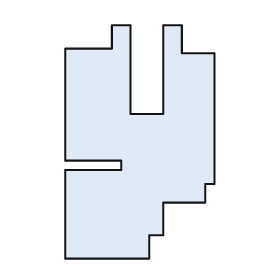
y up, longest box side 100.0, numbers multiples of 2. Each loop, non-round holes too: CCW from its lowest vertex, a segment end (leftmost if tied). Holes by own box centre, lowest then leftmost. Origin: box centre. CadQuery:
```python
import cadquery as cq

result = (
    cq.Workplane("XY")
    .moveTo(-32.0, -50.0)
    .lineTo(4.0, -50.0)
    .lineTo(4.0, -40.0)
    .lineTo(10.0, -40.0)
    .lineTo(10.0, -26.0)
    .lineTo(28.0, -26.0)
    .lineTo(28.0, -18.0)
    .lineTo(32.0, -18.0)
    .lineTo(32.0, 38.0)
    .lineTo(18.0, 38.0)
    .lineTo(18.0, 50.0)
    .lineTo(10.0, 50.0)
    .lineTo(10.0, 12.0)
    .lineTo(-4.0, 12.0)
    .lineTo(-4.0, 50.0)
    .lineTo(-12.0, 50.0)
    .lineTo(-12.0, 40.0)
    .lineTo(-32.0, 40.0)
    .lineTo(-32.0, -8.0)
    .lineTo(-8.0, -8.0)
    .lineTo(-8.0, -12.0)
    .lineTo(-32.0, -12.0)
    .close()
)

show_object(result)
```